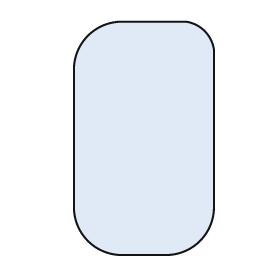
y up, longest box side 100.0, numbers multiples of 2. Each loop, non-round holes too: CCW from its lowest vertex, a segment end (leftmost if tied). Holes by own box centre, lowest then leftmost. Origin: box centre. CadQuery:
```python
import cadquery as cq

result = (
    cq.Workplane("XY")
    .moveTo(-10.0, -50.0)
    .lineTo(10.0, -50.0)
    .threePointArc((24.0, -44.0), (30.0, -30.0))
    .lineTo(30.0, 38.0)
    .threePointArc((26.0, 46.0), (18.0, 50.0))
    .lineTo(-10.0, 50.0)
    .threePointArc((-24.0, 44.0), (-30.0, 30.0))
    .lineTo(-30.0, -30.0)
    .threePointArc((-24.0, -44.0), (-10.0, -50.0))
    .close()
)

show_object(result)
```